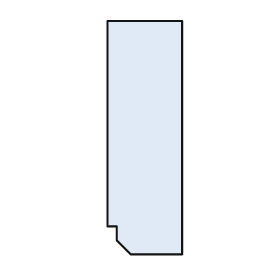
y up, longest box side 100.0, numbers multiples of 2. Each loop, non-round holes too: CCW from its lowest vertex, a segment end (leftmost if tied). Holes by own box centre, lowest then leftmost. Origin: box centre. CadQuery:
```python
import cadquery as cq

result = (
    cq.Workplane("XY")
    .moveTo(-6.0, -50.0)
    .lineTo(16.0, -50.0)
    .lineTo(16.0, 50.0)
    .lineTo(-16.0, 50.0)
    .lineTo(-16.0, -38.0)
    .lineTo(-12.0, -38.0)
    .lineTo(-12.0, -44.0)
    .close()
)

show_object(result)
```